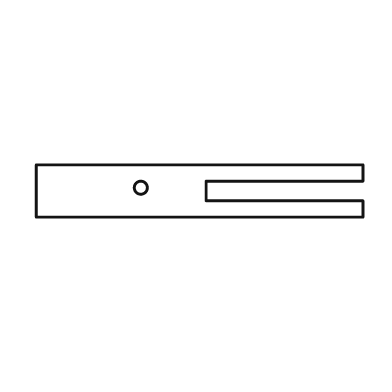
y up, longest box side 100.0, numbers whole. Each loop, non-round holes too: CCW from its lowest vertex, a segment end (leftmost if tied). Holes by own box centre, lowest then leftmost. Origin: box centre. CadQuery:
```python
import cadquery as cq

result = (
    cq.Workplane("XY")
    .moveTo(-50.0, -8.0)
    .lineTo(50.0, -8.0)
    .lineTo(50.0, -3.0)
    .lineTo(2.0, -3.0)
    .lineTo(2.0, 3.0)
    .lineTo(50.0, 3.0)
    .lineTo(50.0, 8.0)
    .lineTo(-50.0, 8.0)
    .close()
    .moveTo(-18.0, 1.0)
    .circle(2.0)
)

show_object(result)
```